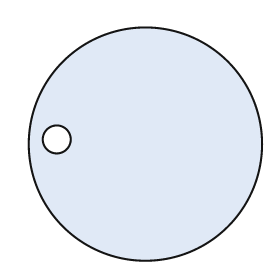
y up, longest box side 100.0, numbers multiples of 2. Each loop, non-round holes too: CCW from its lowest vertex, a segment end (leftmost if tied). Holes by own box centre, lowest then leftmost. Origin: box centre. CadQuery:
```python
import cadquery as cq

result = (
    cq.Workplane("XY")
    .moveTo(0.0, 0.0)
    .circle(50.0)
    .moveTo(-38.0, 2.0)
    .circle(6.0)
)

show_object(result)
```